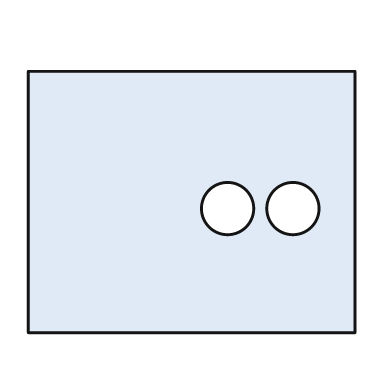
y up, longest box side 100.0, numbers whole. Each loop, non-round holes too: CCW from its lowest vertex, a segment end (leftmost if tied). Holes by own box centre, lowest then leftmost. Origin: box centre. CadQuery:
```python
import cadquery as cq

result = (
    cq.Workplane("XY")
    .moveTo(-50.0, -40.0)
    .lineTo(50.0, -40.0)
    .lineTo(50.0, 40.0)
    .lineTo(-50.0, 40.0)
    .close()
    .moveTo(11.0, -2.0)
    .circle(8.0)
    .moveTo(31.0, -2.0)
    .circle(8.0)
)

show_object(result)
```